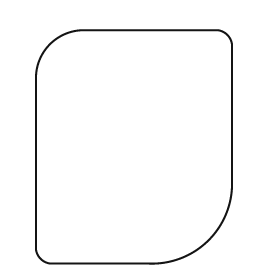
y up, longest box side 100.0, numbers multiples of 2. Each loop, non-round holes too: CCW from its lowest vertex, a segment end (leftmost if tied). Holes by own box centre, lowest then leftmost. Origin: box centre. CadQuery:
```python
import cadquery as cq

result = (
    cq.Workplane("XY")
    .moveTo(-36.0, -50.0)
    .lineTo(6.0, -50.0)
    .threePointArc((32.0, -40.0), (42.0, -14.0))
    .lineTo(42.0, 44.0)
    .threePointArc((40.0, 48.0), (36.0, 50.0))
    .lineTo(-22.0, 50.0)
    .threePointArc((-36.0, 44.0), (-42.0, 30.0))
    .lineTo(-42.0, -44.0)
    .threePointArc((-40.0, -48.0), (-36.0, -50.0))
    .close()
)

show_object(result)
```